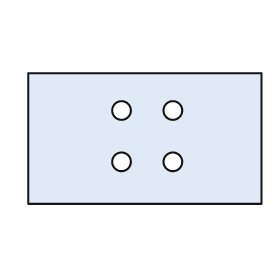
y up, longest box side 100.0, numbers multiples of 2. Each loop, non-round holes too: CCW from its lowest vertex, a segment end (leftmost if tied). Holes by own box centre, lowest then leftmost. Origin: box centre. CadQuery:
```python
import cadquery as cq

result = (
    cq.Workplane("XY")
    .moveTo(-50.0, -28.0)
    .lineTo(50.0, -28.0)
    .lineTo(50.0, 28.0)
    .lineTo(-50.0, 28.0)
    .close()
    .moveTo(-10.0, -10.0)
    .circle(4.0)
    .moveTo(12.0, -10.0)
    .circle(4.0)
    .moveTo(-10.0, 12.0)
    .circle(4.0)
    .moveTo(12.0, 12.0)
    .circle(4.0)
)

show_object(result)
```